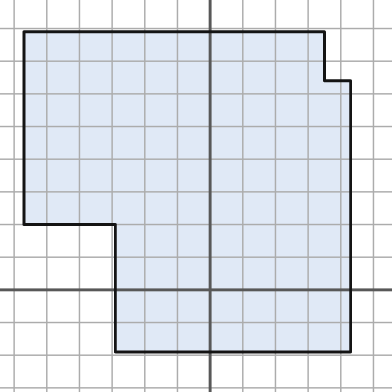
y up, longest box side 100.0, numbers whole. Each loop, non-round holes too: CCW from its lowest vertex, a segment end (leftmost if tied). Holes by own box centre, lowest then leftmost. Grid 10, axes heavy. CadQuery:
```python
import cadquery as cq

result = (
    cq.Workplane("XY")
    .moveTo(-29.0, -19.0)
    .lineTo(43.0, -19.0)
    .lineTo(43.0, 64.0)
    .lineTo(35.0, 64.0)
    .lineTo(35.0, 79.0)
    .lineTo(-57.0, 79.0)
    .lineTo(-57.0, 20.0)
    .lineTo(-29.0, 20.0)
    .close()
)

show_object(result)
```